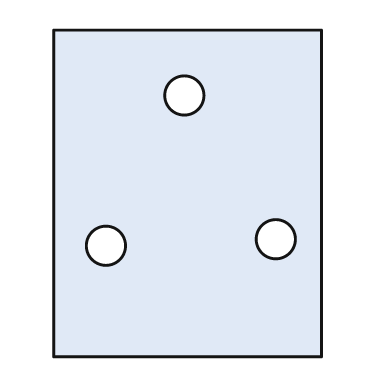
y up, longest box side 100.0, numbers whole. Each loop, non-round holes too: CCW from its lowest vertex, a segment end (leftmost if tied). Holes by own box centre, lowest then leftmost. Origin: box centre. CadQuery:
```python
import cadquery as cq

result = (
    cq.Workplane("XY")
    .moveTo(-41.0, -50.0)
    .lineTo(41.0, -50.0)
    .lineTo(41.0, 50.0)
    .lineTo(-41.0, 50.0)
    .close()
    .moveTo(-25.0, -16.0)
    .circle(6.0)
    .moveTo(27.0, -14.0)
    .circle(6.0)
    .moveTo(-1.0, 30.0)
    .circle(6.0)
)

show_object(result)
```